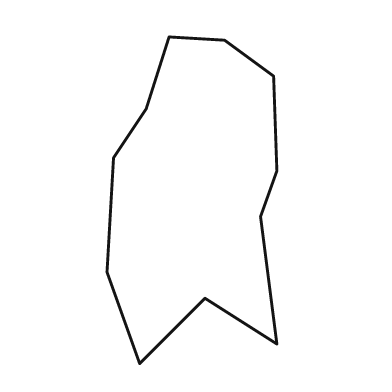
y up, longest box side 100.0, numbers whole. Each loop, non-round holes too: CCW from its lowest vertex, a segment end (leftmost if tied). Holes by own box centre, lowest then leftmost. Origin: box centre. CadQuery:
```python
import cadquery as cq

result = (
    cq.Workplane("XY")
    .moveTo(-16.0, -50.0)
    .lineTo(4.0, -30.0)
    .lineTo(26.0, -44.0)
    .lineTo(21.0, -5.0)
    .lineTo(26.0, 9.0)
    .lineTo(25.0, 38.0)
    .lineTo(10.0, 49.0)
    .lineTo(-7.0, 50.0)
    .lineTo(-14.0, 28.0)
    .lineTo(-24.0, 13.0)
    .lineTo(-26.0, -22.0)
    .close()
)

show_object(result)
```